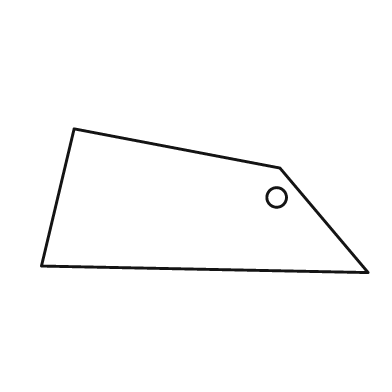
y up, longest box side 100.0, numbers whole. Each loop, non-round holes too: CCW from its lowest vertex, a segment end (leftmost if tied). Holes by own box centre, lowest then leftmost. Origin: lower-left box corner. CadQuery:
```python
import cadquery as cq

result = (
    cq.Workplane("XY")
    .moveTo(100.0, 0.0)
    .lineTo(73.0, 32.0)
    .lineTo(10.0, 44.0)
    .lineTo(0.0, 2.0)
    .close()
    .moveTo(72.0, 23.0)
    .circle(3.0)
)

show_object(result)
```